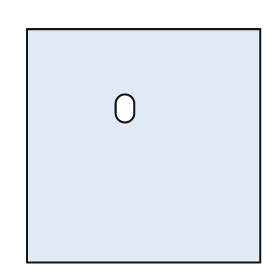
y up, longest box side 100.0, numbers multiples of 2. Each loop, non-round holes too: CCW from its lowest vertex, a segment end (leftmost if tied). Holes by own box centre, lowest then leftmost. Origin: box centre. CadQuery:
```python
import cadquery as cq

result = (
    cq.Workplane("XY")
    .moveTo(-50.0, -50.0)
    .lineTo(50.0, -50.0)
    .lineTo(50.0, 50.0)
    .lineTo(-50.0, 50.0)
    .close()
    .moveTo(-12.0, 14.0)
    .threePointArc((-8.0, 10.0), (-4.0, 14.0))
    .lineTo(-4.0, 18.0)
    .threePointArc((-8.0, 22.0), (-12.0, 18.0))
    .close()
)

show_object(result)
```